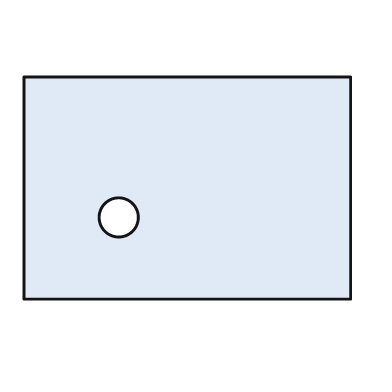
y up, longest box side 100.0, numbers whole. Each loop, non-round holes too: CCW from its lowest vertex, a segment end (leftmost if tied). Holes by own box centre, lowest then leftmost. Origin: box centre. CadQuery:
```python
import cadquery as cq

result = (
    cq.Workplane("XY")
    .moveTo(-50.0, -34.0)
    .lineTo(50.0, -34.0)
    .lineTo(50.0, 34.0)
    .lineTo(-50.0, 34.0)
    .close()
    .moveTo(-21.0, -9.0)
    .circle(6.0)
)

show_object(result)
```